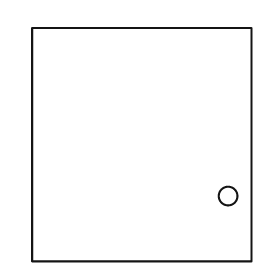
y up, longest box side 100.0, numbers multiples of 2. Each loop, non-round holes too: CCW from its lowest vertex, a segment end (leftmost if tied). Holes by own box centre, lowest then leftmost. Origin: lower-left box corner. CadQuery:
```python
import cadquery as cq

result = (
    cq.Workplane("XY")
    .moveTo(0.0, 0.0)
    .lineTo(94.0, 0.0)
    .lineTo(94.0, 100.0)
    .lineTo(0.0, 100.0)
    .close()
    .moveTo(84.0, 28.0)
    .circle(4.0)
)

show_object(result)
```